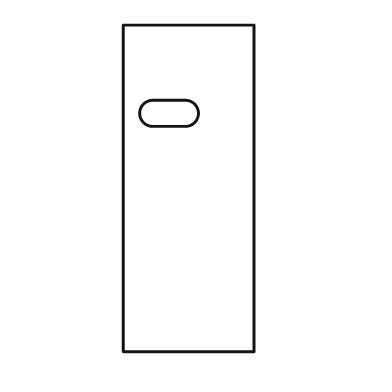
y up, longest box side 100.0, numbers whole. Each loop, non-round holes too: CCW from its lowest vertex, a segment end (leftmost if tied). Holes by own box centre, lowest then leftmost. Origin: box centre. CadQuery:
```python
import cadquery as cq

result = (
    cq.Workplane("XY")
    .moveTo(-20.0, -50.0)
    .lineTo(20.0, -50.0)
    .lineTo(20.0, 50.0)
    .lineTo(-20.0, 50.0)
    .close()
    .moveTo(-11.0, 19.0)
    .lineTo(-1.0, 19.0)
    .threePointArc((3.0, 23.0), (-1.0, 27.0))
    .lineTo(-11.0, 27.0)
    .threePointArc((-15.0, 23.0), (-11.0, 19.0))
    .close()
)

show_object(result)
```